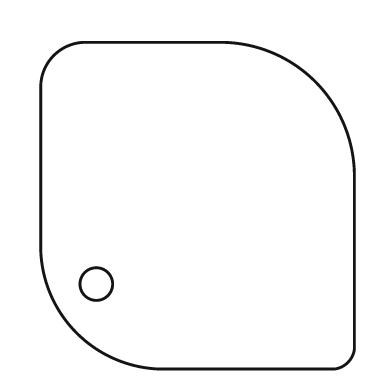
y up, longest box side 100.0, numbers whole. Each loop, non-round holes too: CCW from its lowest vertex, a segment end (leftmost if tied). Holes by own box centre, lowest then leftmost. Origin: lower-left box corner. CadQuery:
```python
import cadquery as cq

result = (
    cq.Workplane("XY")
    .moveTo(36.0, 0.0)
    .lineTo(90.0, 0.0)
    .threePointArc((94.0, 2.0), (96.0, 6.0))
    .lineTo(96.0, 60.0)
    .threePointArc((84.0, 88.0), (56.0, 100.0))
    .lineTo(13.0, 100.0)
    .threePointArc((4.0, 96.0), (0.0, 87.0))
    .lineTo(0.0, 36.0)
    .threePointArc((11.0, 11.0), (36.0, 0.0))
    .close()
    .moveTo(17.0, 26.0)
    .circle(5.0)
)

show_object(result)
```